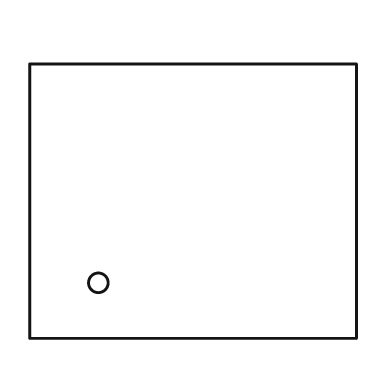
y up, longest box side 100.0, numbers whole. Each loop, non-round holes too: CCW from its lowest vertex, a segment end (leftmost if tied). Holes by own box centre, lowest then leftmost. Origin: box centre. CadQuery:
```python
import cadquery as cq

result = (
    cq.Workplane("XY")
    .moveTo(-50.0, -42.0)
    .lineTo(50.0, -42.0)
    .lineTo(50.0, 42.0)
    .lineTo(-50.0, 42.0)
    .close()
    .moveTo(-29.0, -25.0)
    .circle(3.0)
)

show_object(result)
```